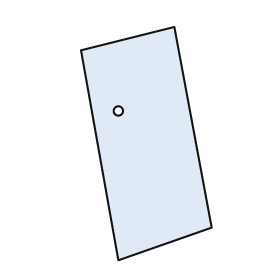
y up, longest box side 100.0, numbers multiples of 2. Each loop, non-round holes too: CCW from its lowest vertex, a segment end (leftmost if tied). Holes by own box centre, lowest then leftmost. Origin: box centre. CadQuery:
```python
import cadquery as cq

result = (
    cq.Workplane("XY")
    .moveTo(-12.0, -50.0)
    .lineTo(28.0, -36.0)
    .lineTo(12.0, 50.0)
    .lineTo(-28.0, 40.0)
    .close()
    .moveTo(-12.0, 14.0)
    .circle(2.0)
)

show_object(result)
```